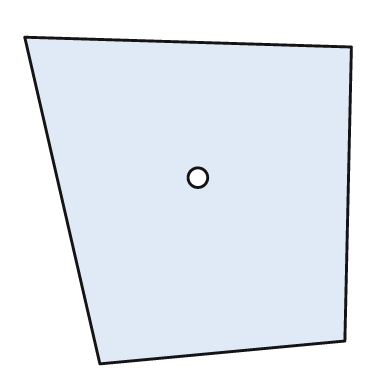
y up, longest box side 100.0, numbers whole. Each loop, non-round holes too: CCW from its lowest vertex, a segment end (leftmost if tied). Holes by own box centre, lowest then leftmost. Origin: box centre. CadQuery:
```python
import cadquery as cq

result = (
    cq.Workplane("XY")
    .moveTo(-27.0, -50.0)
    .lineTo(48.0, -43.0)
    .lineTo(50.0, 47.0)
    .lineTo(-50.0, 50.0)
    .close()
    .moveTo(3.0, 7.0)
    .circle(3.0)
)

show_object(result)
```